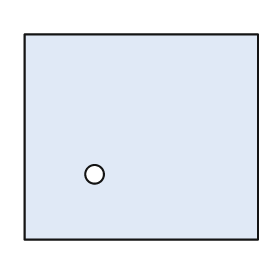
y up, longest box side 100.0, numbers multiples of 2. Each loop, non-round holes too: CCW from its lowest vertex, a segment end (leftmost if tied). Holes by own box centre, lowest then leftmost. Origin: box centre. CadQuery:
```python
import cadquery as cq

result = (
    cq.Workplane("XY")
    .moveTo(-50.0, -44.0)
    .lineTo(50.0, -44.0)
    .lineTo(50.0, 44.0)
    .lineTo(-50.0, 44.0)
    .close()
    .moveTo(-20.0, -16.0)
    .circle(4.0)
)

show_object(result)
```